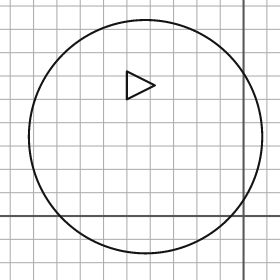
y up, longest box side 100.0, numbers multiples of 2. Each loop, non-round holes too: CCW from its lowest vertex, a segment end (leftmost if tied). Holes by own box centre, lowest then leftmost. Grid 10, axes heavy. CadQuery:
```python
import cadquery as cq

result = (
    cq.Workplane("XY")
    .moveTo(-42.0, 34.0)
    .circle(50.0)
    .moveTo(-50.0, 50.0)
    .lineTo(-38.0, 56.0)
    .lineTo(-50.0, 62.0)
    .close()
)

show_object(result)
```